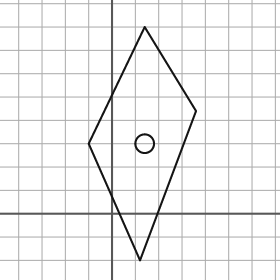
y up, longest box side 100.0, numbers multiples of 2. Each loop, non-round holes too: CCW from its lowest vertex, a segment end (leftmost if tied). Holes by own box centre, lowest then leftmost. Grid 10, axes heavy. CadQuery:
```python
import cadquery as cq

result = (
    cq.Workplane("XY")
    .moveTo(12.0, -20.0)
    .lineTo(36.0, 44.0)
    .lineTo(14.0, 80.0)
    .lineTo(-10.0, 30.0)
    .close()
    .moveTo(14.0, 30.0)
    .circle(4.0)
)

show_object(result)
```